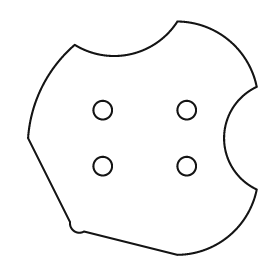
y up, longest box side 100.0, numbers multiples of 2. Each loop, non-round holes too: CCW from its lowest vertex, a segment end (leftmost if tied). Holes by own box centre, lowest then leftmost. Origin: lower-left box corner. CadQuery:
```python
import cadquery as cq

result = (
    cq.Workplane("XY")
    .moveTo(64.0, 0.0)
    .threePointArc((86.0, 8.0), (98.0, 28.0))
    .threePointArc((84.0, 50.0), (98.0, 72.0))
    .threePointArc((86.0, 92.0), (64.0, 100.0))
    .threePointArc((44.0, 86.0), (20.0, 90.0))
    .threePointArc((6.0, 72.0), (0.0, 50.0))
    .lineTo(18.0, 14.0)
    .threePointArc((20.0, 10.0), (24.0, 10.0))
    .close()
    .moveTo(32.0, 38.0)
    .circle(4.0)
    .moveTo(68.0, 38.0)
    .circle(4.0)
    .moveTo(32.0, 62.0)
    .circle(4.0)
    .moveTo(68.0, 62.0)
    .circle(4.0)
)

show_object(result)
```